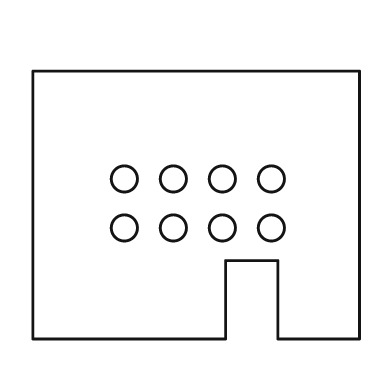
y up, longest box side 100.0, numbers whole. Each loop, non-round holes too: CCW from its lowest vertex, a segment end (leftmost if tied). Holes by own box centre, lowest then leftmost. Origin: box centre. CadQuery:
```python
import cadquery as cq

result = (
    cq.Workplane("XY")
    .moveTo(-50.0, -41.0)
    .lineTo(9.0, -41.0)
    .lineTo(9.0, -17.0)
    .lineTo(25.0, -17.0)
    .lineTo(25.0, -41.0)
    .lineTo(50.0, -41.0)
    .lineTo(50.0, 41.0)
    .lineTo(-50.0, 41.0)
    .close()
    .moveTo(-22.0, -7.0)
    .circle(4.0)
    .moveTo(-7.0, -7.0)
    .circle(4.0)
    .moveTo(8.0, -7.0)
    .circle(4.0)
    .moveTo(23.0, -7.0)
    .circle(4.0)
    .moveTo(-22.0, 8.0)
    .circle(4.0)
    .moveTo(-7.0, 8.0)
    .circle(4.0)
    .moveTo(8.0, 8.0)
    .circle(4.0)
    .moveTo(23.0, 8.0)
    .circle(4.0)
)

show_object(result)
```